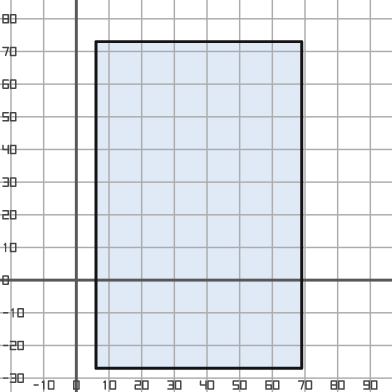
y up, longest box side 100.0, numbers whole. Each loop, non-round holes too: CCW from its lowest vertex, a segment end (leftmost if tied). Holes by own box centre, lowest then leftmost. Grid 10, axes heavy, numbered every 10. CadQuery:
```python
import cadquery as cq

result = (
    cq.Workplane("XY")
    .moveTo(6.0, -27.0)
    .lineTo(69.0, -27.0)
    .lineTo(69.0, 73.0)
    .lineTo(6.0, 73.0)
    .close()
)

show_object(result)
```